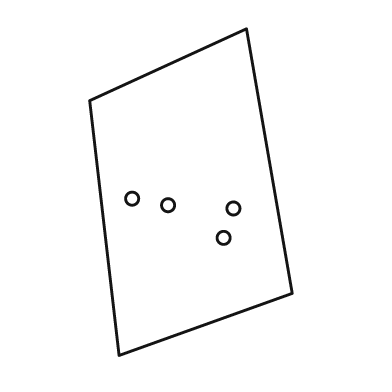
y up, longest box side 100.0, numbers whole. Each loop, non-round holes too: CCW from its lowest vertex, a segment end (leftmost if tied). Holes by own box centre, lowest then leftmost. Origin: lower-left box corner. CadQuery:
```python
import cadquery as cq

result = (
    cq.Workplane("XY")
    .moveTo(9.0, 0.0)
    .lineTo(62.0, 19.0)
    .lineTo(48.0, 100.0)
    .lineTo(0.0, 78.0)
    .close()
    .moveTo(41.0, 36.0)
    .circle(2.0)
    .moveTo(44.0, 45.0)
    .circle(2.0)
    .moveTo(24.0, 46.0)
    .circle(2.0)
    .moveTo(13.0, 48.0)
    .circle(2.0)
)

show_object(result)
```